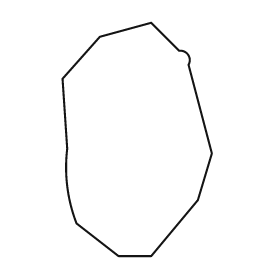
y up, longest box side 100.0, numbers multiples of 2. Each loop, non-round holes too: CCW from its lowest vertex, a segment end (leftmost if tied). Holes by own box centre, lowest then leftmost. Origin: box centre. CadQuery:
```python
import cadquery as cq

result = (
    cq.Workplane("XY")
    .moveTo(-8.0, -50.0)
    .lineTo(6.0, -50.0)
    .lineTo(26.0, -26.0)
    .lineTo(32.0, -6.0)
    .lineTo(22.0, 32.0)
    .threePointArc((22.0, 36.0), (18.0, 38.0))
    .lineTo(6.0, 50.0)
    .lineTo(-16.0, 44.0)
    .lineTo(-32.0, 26.0)
    .lineTo(-30.0, -4.0)
    .threePointArc((-30.0, -20.0), (-26.0, -36.0))
    .close()
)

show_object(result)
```